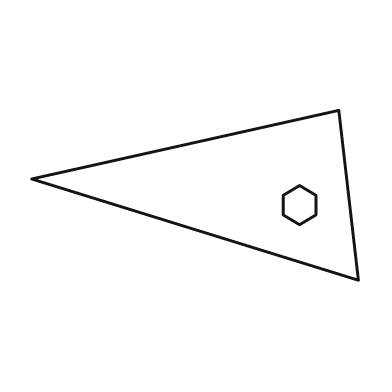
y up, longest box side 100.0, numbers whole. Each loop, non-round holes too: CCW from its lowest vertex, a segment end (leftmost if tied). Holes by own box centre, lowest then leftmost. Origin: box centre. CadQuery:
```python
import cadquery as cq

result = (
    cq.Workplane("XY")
    .moveTo(50.0, -26.0)
    .lineTo(44.0, 26.0)
    .lineTo(-50.0, 5.0)
    .close()
    .moveTo(32.0, -9.0)
    .lineTo(37.0, -6.0)
    .lineTo(37.0, 0.0)
    .lineTo(32.0, 3.0)
    .lineTo(27.0, 0.0)
    .lineTo(27.0, -6.0)
    .close()
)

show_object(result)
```